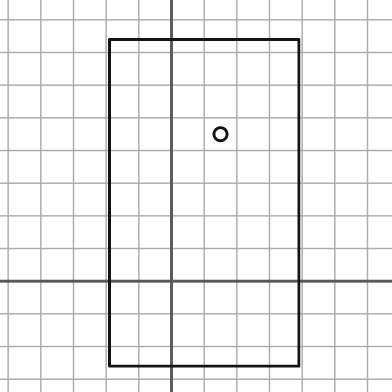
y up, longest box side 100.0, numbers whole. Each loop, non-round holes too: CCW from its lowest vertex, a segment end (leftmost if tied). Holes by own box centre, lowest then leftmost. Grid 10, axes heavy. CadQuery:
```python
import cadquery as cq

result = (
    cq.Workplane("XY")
    .moveTo(-19.0, -26.0)
    .lineTo(39.0, -26.0)
    .lineTo(39.0, 74.0)
    .lineTo(-19.0, 74.0)
    .close()
    .moveTo(15.0, 45.0)
    .circle(2.0)
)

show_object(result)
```